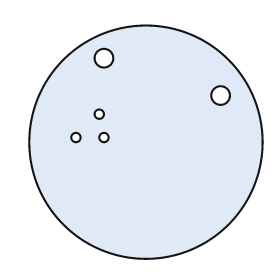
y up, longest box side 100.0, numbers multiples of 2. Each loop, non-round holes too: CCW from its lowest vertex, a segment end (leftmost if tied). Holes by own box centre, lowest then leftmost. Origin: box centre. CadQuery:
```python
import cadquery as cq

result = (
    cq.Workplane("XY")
    .moveTo(0.0, 0.0)
    .circle(50.0)
    .moveTo(-30.0, 2.0)
    .circle(2.0)
    .moveTo(-18.0, 2.0)
    .circle(2.0)
    .moveTo(-20.0, 12.0)
    .circle(2.0)
    .moveTo(32.0, 20.0)
    .circle(4.0)
    .moveTo(-18.0, 36.0)
    .circle(4.0)
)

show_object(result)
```